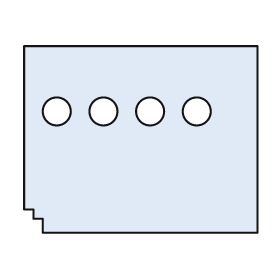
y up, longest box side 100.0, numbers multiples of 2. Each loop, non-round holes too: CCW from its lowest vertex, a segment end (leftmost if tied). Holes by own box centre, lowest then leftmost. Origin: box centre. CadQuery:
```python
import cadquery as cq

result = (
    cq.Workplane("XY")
    .moveTo(-42.0, -40.0)
    .lineTo(50.0, -40.0)
    .lineTo(50.0, 40.0)
    .lineTo(-50.0, 40.0)
    .lineTo(-50.0, -30.0)
    .lineTo(-46.0, -30.0)
    .lineTo(-46.0, -34.0)
    .lineTo(-42.0, -34.0)
    .close()
    .moveTo(-36.0, 12.0)
    .circle(6.0)
    .moveTo(-16.0, 12.0)
    .circle(6.0)
    .moveTo(4.0, 12.0)
    .circle(6.0)
    .moveTo(24.0, 12.0)
    .circle(6.0)
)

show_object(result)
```